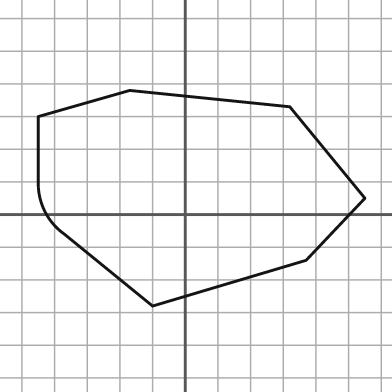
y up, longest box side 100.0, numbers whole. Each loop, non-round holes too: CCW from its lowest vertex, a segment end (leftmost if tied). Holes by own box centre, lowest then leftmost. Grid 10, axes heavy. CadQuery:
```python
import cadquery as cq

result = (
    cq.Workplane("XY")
    .moveTo(-10.0, -28.0)
    .lineTo(37.0, -14.0)
    .lineTo(55.0, 5.0)
    .lineTo(32.0, 33.0)
    .lineTo(-17.0, 38.0)
    .lineTo(-45.0, 30.0)
    .lineTo(-45.0, 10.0)
    .threePointArc((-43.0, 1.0), (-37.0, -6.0))
    .close()
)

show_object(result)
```